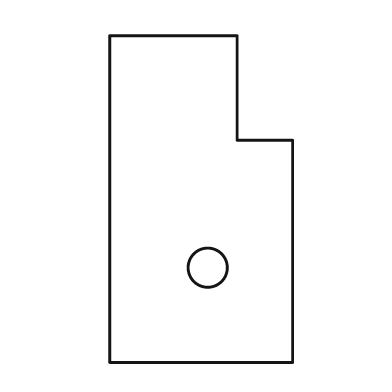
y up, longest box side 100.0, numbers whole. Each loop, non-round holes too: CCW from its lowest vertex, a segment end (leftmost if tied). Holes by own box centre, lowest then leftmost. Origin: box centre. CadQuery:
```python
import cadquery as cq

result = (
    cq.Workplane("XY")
    .moveTo(-28.0, -50.0)
    .lineTo(28.0, -50.0)
    .lineTo(28.0, 18.0)
    .lineTo(11.0, 18.0)
    .lineTo(11.0, 50.0)
    .lineTo(-28.0, 50.0)
    .close()
    .moveTo(2.0, -21.0)
    .circle(6.0)
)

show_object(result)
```